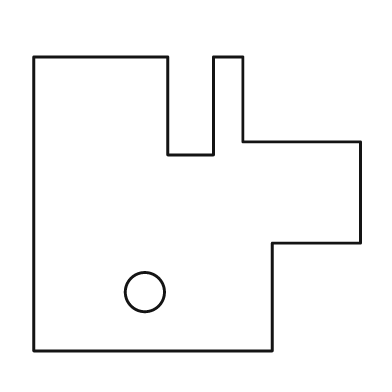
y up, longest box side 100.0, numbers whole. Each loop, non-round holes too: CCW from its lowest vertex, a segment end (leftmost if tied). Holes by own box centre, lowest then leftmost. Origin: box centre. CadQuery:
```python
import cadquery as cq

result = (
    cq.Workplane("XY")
    .moveTo(-50.0, -45.0)
    .lineTo(23.0, -45.0)
    .lineTo(23.0, -12.0)
    .lineTo(50.0, -12.0)
    .lineTo(50.0, 19.0)
    .lineTo(14.0, 19.0)
    .lineTo(14.0, 45.0)
    .lineTo(5.0, 45.0)
    .lineTo(5.0, 15.0)
    .lineTo(-9.0, 15.0)
    .lineTo(-9.0, 45.0)
    .lineTo(-50.0, 45.0)
    .close()
    .moveTo(-16.0, -27.0)
    .circle(6.0)
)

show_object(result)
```